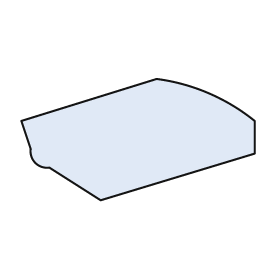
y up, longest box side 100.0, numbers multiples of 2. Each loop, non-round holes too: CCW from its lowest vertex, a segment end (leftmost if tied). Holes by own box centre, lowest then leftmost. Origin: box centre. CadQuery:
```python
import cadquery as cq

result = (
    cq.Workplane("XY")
    .moveTo(-16.0, -26.0)
    .lineTo(50.0, -6.0)
    .lineTo(50.0, 8.0)
    .threePointArc((30.0, 20.0), (8.0, 26.0))
    .lineTo(-50.0, 8.0)
    .lineTo(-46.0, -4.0)
    .threePointArc((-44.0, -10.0), (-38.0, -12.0))
    .close()
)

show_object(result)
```